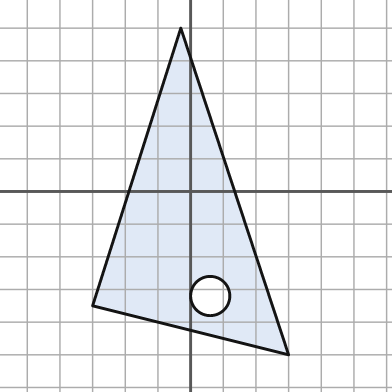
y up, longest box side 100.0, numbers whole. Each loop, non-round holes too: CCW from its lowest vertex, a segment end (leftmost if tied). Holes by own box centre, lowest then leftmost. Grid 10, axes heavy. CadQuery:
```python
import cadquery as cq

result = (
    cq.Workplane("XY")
    .moveTo(30.0, -50.0)
    .lineTo(-3.0, 50.0)
    .lineTo(-30.0, -35.0)
    .close()
    .moveTo(6.0, -32.0)
    .circle(6.0)
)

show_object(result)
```